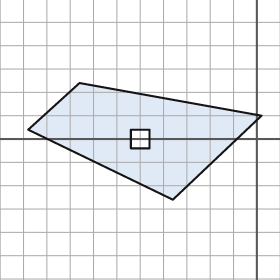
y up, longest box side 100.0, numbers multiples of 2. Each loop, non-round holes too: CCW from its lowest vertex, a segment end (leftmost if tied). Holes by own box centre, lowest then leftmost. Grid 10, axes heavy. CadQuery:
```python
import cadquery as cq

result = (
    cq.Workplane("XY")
    .moveTo(-36.0, -26.0)
    .lineTo(2.0, 10.0)
    .lineTo(-76.0, 24.0)
    .lineTo(-98.0, 4.0)
    .close()
    .moveTo(-54.0, -4.0)
    .lineTo(-46.0, -4.0)
    .lineTo(-46.0, 4.0)
    .lineTo(-54.0, 4.0)
    .close()
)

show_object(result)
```